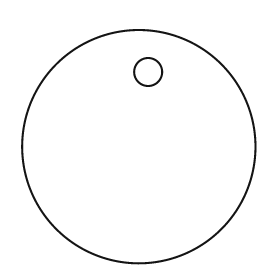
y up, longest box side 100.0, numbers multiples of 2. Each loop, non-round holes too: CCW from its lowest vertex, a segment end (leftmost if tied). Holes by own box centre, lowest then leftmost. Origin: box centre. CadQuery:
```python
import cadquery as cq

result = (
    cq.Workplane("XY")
    .moveTo(0.0, 0.0)
    .circle(50.0)
    .moveTo(4.0, 32.0)
    .circle(6.0)
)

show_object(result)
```